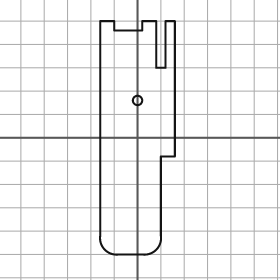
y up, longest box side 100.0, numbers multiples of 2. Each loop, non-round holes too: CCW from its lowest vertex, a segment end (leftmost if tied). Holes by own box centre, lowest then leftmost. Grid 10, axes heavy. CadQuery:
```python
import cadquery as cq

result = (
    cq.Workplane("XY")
    .moveTo(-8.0, -50.0)
    .lineTo(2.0, -50.0)
    .threePointArc((8.0, -48.0), (10.0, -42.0))
    .lineTo(10.0, -8.0)
    .lineTo(16.0, -8.0)
    .lineTo(16.0, 50.0)
    .lineTo(12.0, 50.0)
    .lineTo(12.0, 30.0)
    .lineTo(8.0, 30.0)
    .lineTo(8.0, 50.0)
    .lineTo(2.0, 50.0)
    .lineTo(2.0, 46.0)
    .lineTo(-10.0, 46.0)
    .lineTo(-10.0, 50.0)
    .lineTo(-16.0, 50.0)
    .lineTo(-16.0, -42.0)
    .threePointArc((-14.0, -48.0), (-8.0, -50.0))
    .close()
    .moveTo(0.0, 16.0)
    .circle(2.0)
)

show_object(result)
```